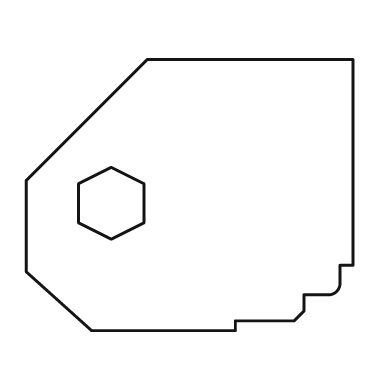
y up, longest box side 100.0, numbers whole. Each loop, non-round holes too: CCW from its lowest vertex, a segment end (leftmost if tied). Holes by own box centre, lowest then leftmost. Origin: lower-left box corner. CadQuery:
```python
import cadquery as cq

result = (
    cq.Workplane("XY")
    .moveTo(20.0, 0.0)
    .lineTo(64.0, 0.0)
    .lineTo(64.0, 3.0)
    .lineTo(82.0, 3.0)
    .lineTo(85.0, 6.0)
    .lineTo(85.0, 11.0)
    .lineTo(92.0, 11.0)
    .threePointArc((95.0, 12.0), (96.0, 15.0))
    .lineTo(96.0, 20.0)
    .lineTo(100.0, 20.0)
    .lineTo(100.0, 83.0)
    .lineTo(37.0, 83.0)
    .lineTo(0.0, 46.0)
    .lineTo(0.0, 18.0)
    .close()
    .moveTo(26.0, 28.0)
    .lineTo(36.0, 33.0)
    .lineTo(36.0, 45.0)
    .lineTo(26.0, 50.0)
    .lineTo(16.0, 45.0)
    .lineTo(16.0, 33.0)
    .close()
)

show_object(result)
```